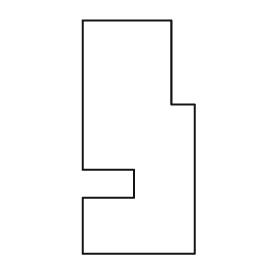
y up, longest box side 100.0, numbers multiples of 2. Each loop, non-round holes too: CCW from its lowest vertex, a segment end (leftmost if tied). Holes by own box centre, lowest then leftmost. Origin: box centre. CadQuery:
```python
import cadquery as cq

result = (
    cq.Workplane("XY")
    .moveTo(-24.0, -50.0)
    .lineTo(24.0, -50.0)
    .lineTo(24.0, 14.0)
    .lineTo(14.0, 14.0)
    .lineTo(14.0, 50.0)
    .lineTo(-24.0, 50.0)
    .lineTo(-24.0, -14.0)
    .lineTo(-2.0, -14.0)
    .lineTo(-2.0, -26.0)
    .lineTo(-24.0, -26.0)
    .close()
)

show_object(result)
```